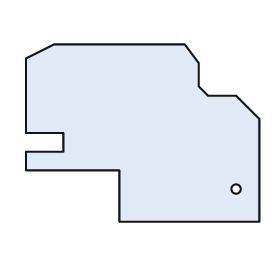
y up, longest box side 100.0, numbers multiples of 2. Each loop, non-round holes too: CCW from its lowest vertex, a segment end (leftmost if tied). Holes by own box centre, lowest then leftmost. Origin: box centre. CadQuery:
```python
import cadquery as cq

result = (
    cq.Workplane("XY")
    .moveTo(-10.0, -38.0)
    .lineTo(50.0, -38.0)
    .lineTo(50.0, 6.0)
    .lineTo(40.0, 16.0)
    .lineTo(28.0, 16.0)
    .lineTo(24.0, 20.0)
    .lineTo(24.0, 30.0)
    .lineTo(18.0, 38.0)
    .lineTo(-38.0, 38.0)
    .lineTo(-50.0, 32.0)
    .lineTo(-50.0, 0.0)
    .lineTo(-34.0, 0.0)
    .lineTo(-34.0, -8.0)
    .lineTo(-50.0, -8.0)
    .lineTo(-50.0, -16.0)
    .lineTo(-10.0, -16.0)
    .close()
    .moveTo(40.0, -24.0)
    .circle(2.0)
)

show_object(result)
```